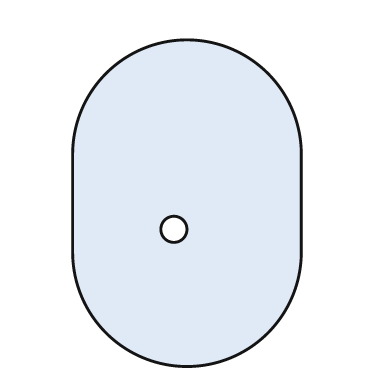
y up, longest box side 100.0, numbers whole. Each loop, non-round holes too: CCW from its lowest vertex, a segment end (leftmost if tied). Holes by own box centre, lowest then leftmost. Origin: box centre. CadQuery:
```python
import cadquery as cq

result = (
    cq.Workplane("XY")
    .moveTo(-35.0, -15.0)
    .threePointArc((0.0, -50.0), (35.0, -15.0))
    .lineTo(35.0, 15.0)
    .threePointArc((0.0, 50.0), (-35.0, 15.0))
    .close()
    .moveTo(-4.0, -8.0)
    .circle(4.0)
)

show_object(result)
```